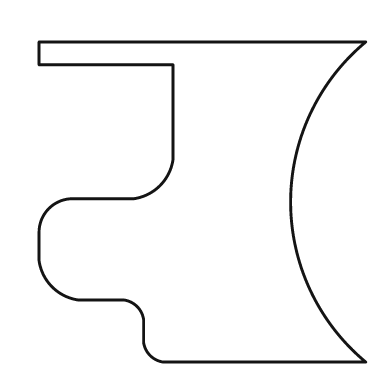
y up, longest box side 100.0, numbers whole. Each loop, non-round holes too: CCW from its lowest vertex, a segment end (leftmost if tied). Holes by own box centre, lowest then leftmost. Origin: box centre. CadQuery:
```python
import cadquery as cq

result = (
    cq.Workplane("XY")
    .moveTo(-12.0, -49.0)
    .lineTo(50.0, -49.0)
    .threePointArc((27.0, 0.0), (50.0, 49.0))
    .lineTo(-50.0, 49.0)
    .lineTo(-50.0, 42.0)
    .lineTo(-9.0, 42.0)
    .lineTo(-9.0, 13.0)
    .threePointArc((-13.0, 5.0), (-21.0, 1.0))
    .lineTo(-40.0, 1.0)
    .threePointArc((-47.0, -2.0), (-50.0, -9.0))
    .lineTo(-50.0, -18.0)
    .threePointArc((-46.0, -26.0), (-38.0, -30.0))
    .lineTo(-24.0, -30.0)
    .threePointArc((-20.0, -32.0), (-18.0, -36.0))
    .lineTo(-18.0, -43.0)
    .threePointArc((-16.0, -47.0), (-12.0, -49.0))
    .close()
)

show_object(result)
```